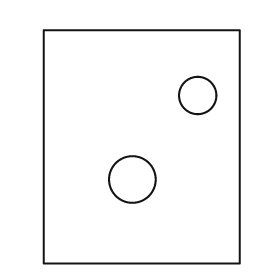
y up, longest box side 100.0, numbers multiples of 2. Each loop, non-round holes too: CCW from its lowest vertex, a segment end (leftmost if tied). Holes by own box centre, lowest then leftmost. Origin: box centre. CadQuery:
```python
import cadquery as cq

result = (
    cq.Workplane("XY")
    .moveTo(-42.0, -50.0)
    .lineTo(42.0, -50.0)
    .lineTo(42.0, 50.0)
    .lineTo(-42.0, 50.0)
    .close()
    .moveTo(-4.0, -14.0)
    .circle(10.0)
    .moveTo(24.0, 22.0)
    .circle(8.0)
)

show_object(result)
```